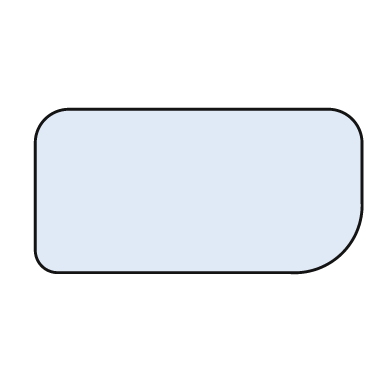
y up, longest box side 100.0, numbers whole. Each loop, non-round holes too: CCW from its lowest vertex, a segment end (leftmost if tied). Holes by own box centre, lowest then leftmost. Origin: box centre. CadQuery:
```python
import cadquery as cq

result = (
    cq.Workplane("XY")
    .moveTo(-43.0, -25.0)
    .lineTo(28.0, -25.0)
    .threePointArc((44.0, -19.0), (50.0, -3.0))
    .lineTo(50.0, 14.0)
    .threePointArc((47.0, 22.0), (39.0, 25.0))
    .lineTo(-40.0, 25.0)
    .threePointArc((-47.0, 22.0), (-50.0, 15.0))
    .lineTo(-50.0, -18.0)
    .threePointArc((-48.0, -23.0), (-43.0, -25.0))
    .close()
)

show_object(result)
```